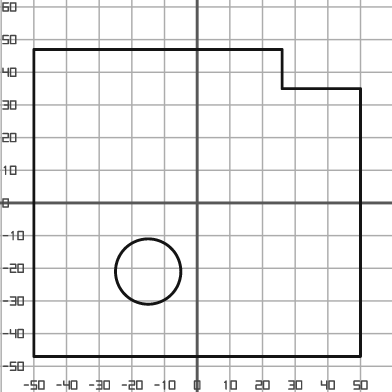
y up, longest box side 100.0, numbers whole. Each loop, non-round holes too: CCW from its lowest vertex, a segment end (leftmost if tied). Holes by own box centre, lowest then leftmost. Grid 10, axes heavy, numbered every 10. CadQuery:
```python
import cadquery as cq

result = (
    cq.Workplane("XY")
    .moveTo(-50.0, -47.0)
    .lineTo(50.0, -47.0)
    .lineTo(50.0, 35.0)
    .lineTo(26.0, 35.0)
    .lineTo(26.0, 47.0)
    .lineTo(-50.0, 47.0)
    .close()
    .moveTo(-15.0, -21.0)
    .circle(10.0)
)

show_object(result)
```